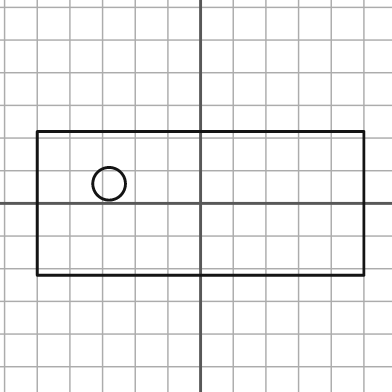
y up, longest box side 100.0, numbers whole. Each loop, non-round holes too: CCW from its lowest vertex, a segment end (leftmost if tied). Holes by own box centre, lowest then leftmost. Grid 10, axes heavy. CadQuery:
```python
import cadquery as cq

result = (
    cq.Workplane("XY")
    .moveTo(-50.0, -22.0)
    .lineTo(50.0, -22.0)
    .lineTo(50.0, 22.0)
    .lineTo(-50.0, 22.0)
    .close()
    .moveTo(-28.0, 6.0)
    .circle(5.0)
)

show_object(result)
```